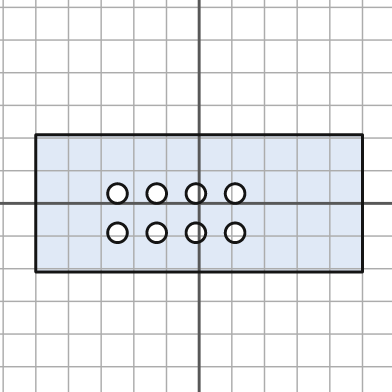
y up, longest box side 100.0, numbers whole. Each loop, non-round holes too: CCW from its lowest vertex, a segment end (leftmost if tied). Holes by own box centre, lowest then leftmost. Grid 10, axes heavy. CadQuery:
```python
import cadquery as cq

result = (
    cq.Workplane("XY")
    .moveTo(-50.0, -21.0)
    .lineTo(50.0, -21.0)
    .lineTo(50.0, 21.0)
    .lineTo(-50.0, 21.0)
    .close()
    .moveTo(-25.0, -9.0)
    .circle(3.0)
    .moveTo(-13.0, -9.0)
    .circle(3.0)
    .moveTo(-1.0, -9.0)
    .circle(3.0)
    .moveTo(11.0, -9.0)
    .circle(3.0)
    .moveTo(-25.0, 3.0)
    .circle(3.0)
    .moveTo(-13.0, 3.0)
    .circle(3.0)
    .moveTo(-1.0, 3.0)
    .circle(3.0)
    .moveTo(11.0, 3.0)
    .circle(3.0)
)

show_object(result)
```